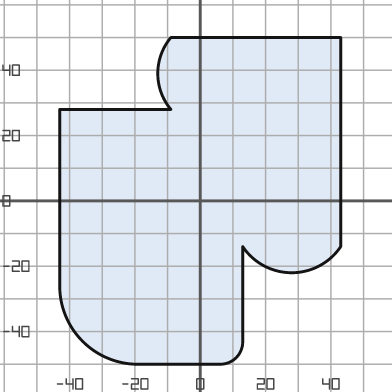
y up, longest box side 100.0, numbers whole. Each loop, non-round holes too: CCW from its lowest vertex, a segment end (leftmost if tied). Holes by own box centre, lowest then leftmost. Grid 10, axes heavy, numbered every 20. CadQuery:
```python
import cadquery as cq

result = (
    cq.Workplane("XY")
    .moveTo(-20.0, -50.0)
    .lineTo(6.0, -50.0)
    .threePointArc((11.0, -48.0), (13.0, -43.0))
    .lineTo(13.0, -14.0)
    .threePointArc((28.0, -22.0), (43.0, -14.0))
    .lineTo(43.0, 50.0)
    .lineTo(-9.0, 50.0)
    .threePointArc((-13.0, 39.0), (-9.0, 28.0))
    .lineTo(-43.0, 28.0)
    .lineTo(-43.0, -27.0)
    .threePointArc((-36.0, -43.0), (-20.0, -50.0))
    .close()
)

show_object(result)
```